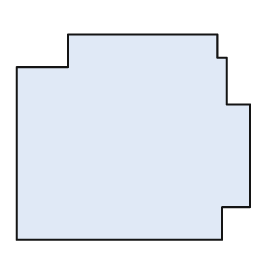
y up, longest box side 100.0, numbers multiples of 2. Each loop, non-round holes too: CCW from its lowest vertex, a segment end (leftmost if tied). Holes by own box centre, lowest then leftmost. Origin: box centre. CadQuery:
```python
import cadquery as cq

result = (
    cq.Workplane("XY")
    .moveTo(-50.0, -44.0)
    .lineTo(38.0, -44.0)
    .lineTo(38.0, -30.0)
    .lineTo(50.0, -30.0)
    .lineTo(50.0, 14.0)
    .lineTo(40.0, 14.0)
    .lineTo(40.0, 34.0)
    .lineTo(36.0, 34.0)
    .lineTo(36.0, 44.0)
    .lineTo(-28.0, 44.0)
    .lineTo(-28.0, 30.0)
    .lineTo(-50.0, 30.0)
    .close()
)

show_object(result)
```